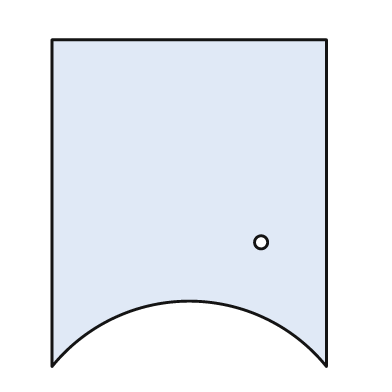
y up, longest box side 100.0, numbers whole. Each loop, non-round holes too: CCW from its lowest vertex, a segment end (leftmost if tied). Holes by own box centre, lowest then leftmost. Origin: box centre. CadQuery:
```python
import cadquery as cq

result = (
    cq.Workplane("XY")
    .moveTo(-42.0, -50.0)
    .threePointArc((0.0, -30.0), (42.0, -50.0))
    .lineTo(42.0, 50.0)
    .lineTo(-42.0, 50.0)
    .close()
    .moveTo(22.0, -12.0)
    .circle(2.0)
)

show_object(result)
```